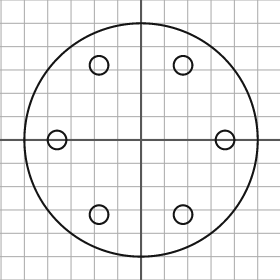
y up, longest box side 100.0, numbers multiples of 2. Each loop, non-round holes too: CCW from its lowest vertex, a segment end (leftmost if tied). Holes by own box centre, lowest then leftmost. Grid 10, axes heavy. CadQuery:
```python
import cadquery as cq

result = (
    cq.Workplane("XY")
    .moveTo(0.0, 0.0)
    .circle(50.0)
    .moveTo(-18.0, -32.0)
    .circle(4.0)
    .moveTo(18.0, -32.0)
    .circle(4.0)
    .moveTo(-36.0, 0.0)
    .circle(4.0)
    .moveTo(36.0, 0.0)
    .circle(4.0)
    .moveTo(-18.0, 32.0)
    .circle(4.0)
    .moveTo(18.0, 32.0)
    .circle(4.0)
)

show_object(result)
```